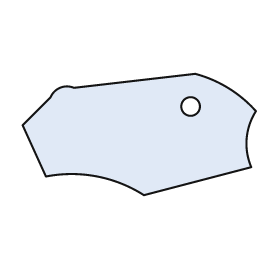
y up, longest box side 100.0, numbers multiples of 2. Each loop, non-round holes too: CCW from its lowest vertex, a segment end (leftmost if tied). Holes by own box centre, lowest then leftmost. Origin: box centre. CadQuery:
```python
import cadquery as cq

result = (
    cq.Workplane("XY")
    .moveTo(2.0, -26.0)
    .lineTo(48.0, -14.0)
    .threePointArc((46.0, -2.0), (50.0, 10.0))
    .threePointArc((38.0, 20.0), (24.0, 26.0))
    .lineTo(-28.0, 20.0)
    .threePointArc((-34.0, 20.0), (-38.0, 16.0))
    .lineTo(-50.0, 4.0)
    .lineTo(-40.0, -18.0)
    .threePointArc((-18.0, -18.0), (2.0, -26.0))
    .close()
    .moveTo(22.0, 12.0)
    .circle(4.0)
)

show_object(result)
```